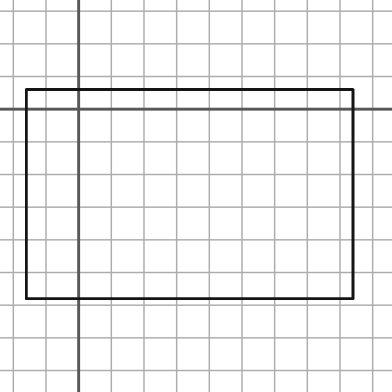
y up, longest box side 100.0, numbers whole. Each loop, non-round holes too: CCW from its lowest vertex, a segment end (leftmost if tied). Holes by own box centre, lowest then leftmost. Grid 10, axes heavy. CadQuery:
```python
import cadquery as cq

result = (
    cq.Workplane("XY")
    .moveTo(-16.0, -58.0)
    .lineTo(84.0, -58.0)
    .lineTo(84.0, 6.0)
    .lineTo(-16.0, 6.0)
    .close()
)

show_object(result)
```